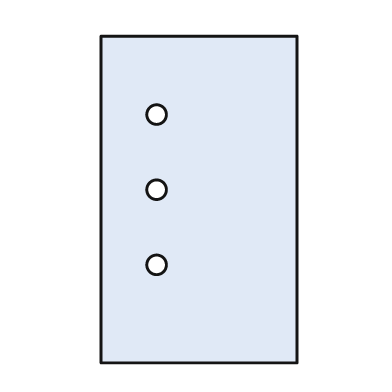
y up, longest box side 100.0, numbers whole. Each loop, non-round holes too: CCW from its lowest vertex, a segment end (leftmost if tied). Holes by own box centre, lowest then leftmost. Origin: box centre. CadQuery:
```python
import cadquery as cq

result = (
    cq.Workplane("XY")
    .moveTo(-30.0, -50.0)
    .lineTo(30.0, -50.0)
    .lineTo(30.0, 50.0)
    .lineTo(-30.0, 50.0)
    .close()
    .moveTo(-13.0, -20.0)
    .circle(3.0)
    .moveTo(-13.0, 3.0)
    .circle(3.0)
    .moveTo(-13.0, 26.0)
    .circle(3.0)
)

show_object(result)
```